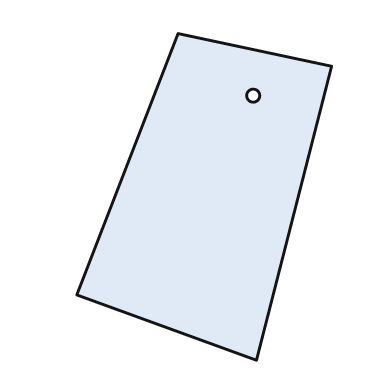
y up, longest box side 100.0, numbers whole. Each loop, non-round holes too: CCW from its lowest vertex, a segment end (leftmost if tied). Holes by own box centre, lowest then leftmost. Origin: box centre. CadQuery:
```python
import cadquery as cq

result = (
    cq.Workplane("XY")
    .moveTo(16.0, -50.0)
    .lineTo(39.0, 40.0)
    .lineTo(-8.0, 50.0)
    .lineTo(-39.0, -30.0)
    .close()
    .moveTo(15.0, 31.0)
    .circle(2.0)
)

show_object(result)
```